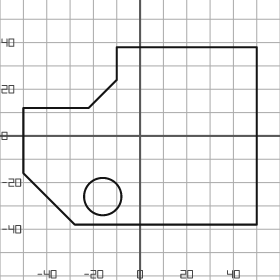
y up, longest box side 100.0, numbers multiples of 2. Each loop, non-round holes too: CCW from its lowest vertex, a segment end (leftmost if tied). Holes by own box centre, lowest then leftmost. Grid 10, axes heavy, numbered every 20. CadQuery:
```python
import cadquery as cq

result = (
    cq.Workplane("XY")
    .moveTo(-28.0, -38.0)
    .lineTo(50.0, -38.0)
    .lineTo(50.0, 38.0)
    .lineTo(-10.0, 38.0)
    .lineTo(-10.0, 24.0)
    .lineTo(-22.0, 12.0)
    .lineTo(-50.0, 12.0)
    .lineTo(-50.0, -16.0)
    .close()
    .moveTo(-16.0, -26.0)
    .circle(8.0)
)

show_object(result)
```